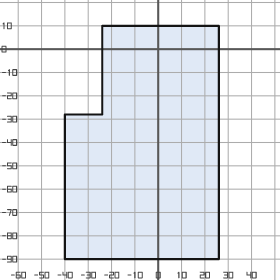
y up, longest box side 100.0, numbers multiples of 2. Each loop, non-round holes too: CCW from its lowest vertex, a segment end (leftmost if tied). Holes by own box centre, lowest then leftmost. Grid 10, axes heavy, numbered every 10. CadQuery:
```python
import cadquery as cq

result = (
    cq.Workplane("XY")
    .moveTo(-40.0, -90.0)
    .lineTo(26.0, -90.0)
    .lineTo(26.0, 10.0)
    .lineTo(-24.0, 10.0)
    .lineTo(-24.0, -28.0)
    .lineTo(-40.0, -28.0)
    .close()
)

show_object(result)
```